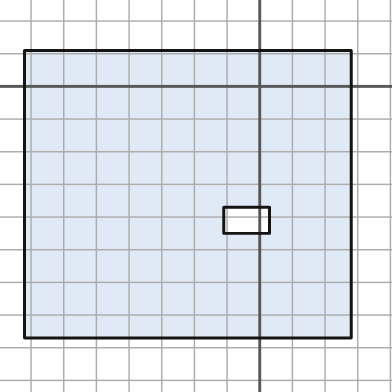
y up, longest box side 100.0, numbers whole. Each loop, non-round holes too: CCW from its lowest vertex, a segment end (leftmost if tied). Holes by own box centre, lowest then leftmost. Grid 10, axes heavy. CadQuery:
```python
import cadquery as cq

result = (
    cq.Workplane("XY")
    .moveTo(-72.0, -77.0)
    .lineTo(28.0, -77.0)
    .lineTo(28.0, 11.0)
    .lineTo(-72.0, 11.0)
    .close()
    .moveTo(-11.0, -45.0)
    .lineTo(3.0, -45.0)
    .lineTo(3.0, -37.0)
    .lineTo(-11.0, -37.0)
    .close()
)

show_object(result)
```